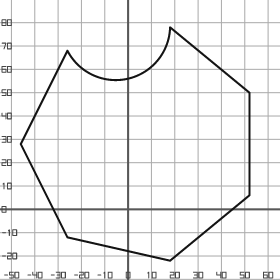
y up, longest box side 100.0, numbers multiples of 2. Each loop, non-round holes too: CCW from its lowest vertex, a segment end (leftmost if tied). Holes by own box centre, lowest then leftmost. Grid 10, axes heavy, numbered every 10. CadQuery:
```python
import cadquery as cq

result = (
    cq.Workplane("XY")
    .moveTo(18.0, -22.0)
    .lineTo(52.0, 6.0)
    .lineTo(52.0, 50.0)
    .lineTo(18.0, 78.0)
    .threePointArc((0.0, 56.0), (-26.0, 68.0))
    .lineTo(-46.0, 28.0)
    .lineTo(-26.0, -12.0)
    .close()
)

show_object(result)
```